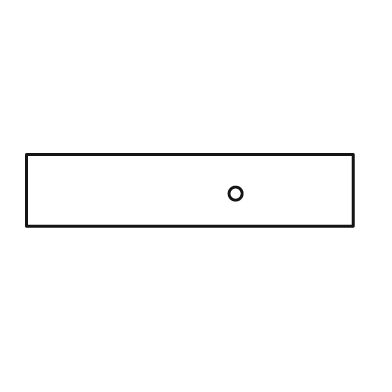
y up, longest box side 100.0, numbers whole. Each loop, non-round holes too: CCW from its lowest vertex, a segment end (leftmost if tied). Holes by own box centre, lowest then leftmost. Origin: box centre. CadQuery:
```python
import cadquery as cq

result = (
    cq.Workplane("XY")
    .moveTo(-50.0, -11.0)
    .lineTo(50.0, -11.0)
    .lineTo(50.0, 11.0)
    .lineTo(-50.0, 11.0)
    .close()
    .moveTo(14.0, -1.0)
    .circle(2.0)
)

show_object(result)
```